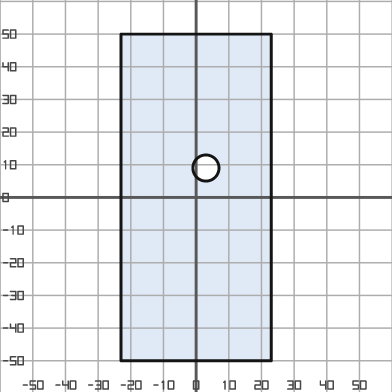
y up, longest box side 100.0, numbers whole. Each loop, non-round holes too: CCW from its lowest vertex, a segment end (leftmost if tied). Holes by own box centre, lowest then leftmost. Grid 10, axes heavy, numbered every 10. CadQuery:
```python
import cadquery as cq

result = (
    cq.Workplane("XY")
    .moveTo(-23.0, -50.0)
    .lineTo(23.0, -50.0)
    .lineTo(23.0, 50.0)
    .lineTo(-23.0, 50.0)
    .close()
    .moveTo(3.0, 9.0)
    .circle(4.0)
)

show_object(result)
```